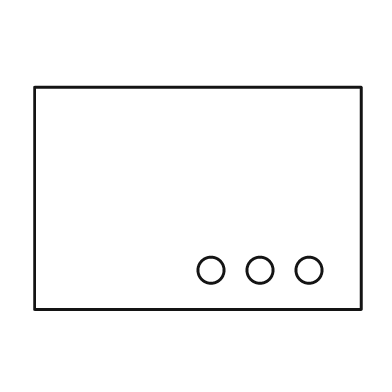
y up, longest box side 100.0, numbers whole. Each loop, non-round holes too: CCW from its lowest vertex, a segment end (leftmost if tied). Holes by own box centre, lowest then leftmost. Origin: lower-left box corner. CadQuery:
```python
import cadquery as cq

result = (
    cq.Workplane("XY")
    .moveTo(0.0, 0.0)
    .lineTo(100.0, 0.0)
    .lineTo(100.0, 68.0)
    .lineTo(0.0, 68.0)
    .close()
    .moveTo(54.0, 12.0)
    .circle(4.0)
    .moveTo(69.0, 12.0)
    .circle(4.0)
    .moveTo(84.0, 12.0)
    .circle(4.0)
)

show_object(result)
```